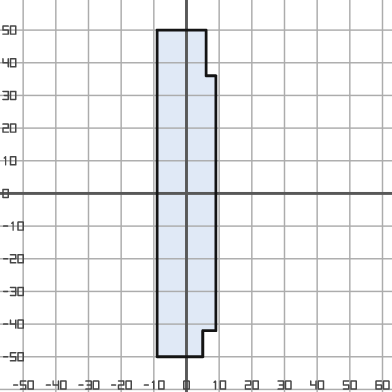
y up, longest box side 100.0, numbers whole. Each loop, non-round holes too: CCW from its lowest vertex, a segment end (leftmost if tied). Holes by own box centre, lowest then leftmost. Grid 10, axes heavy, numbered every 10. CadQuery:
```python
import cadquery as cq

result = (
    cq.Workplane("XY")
    .moveTo(-9.0, -50.0)
    .lineTo(5.0, -50.0)
    .lineTo(5.0, -42.0)
    .lineTo(9.0, -42.0)
    .lineTo(9.0, 36.0)
    .lineTo(6.0, 36.0)
    .lineTo(6.0, 50.0)
    .lineTo(-9.0, 50.0)
    .close()
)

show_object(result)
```